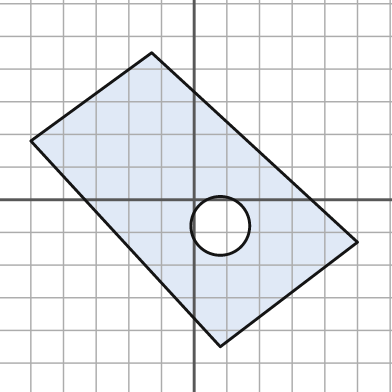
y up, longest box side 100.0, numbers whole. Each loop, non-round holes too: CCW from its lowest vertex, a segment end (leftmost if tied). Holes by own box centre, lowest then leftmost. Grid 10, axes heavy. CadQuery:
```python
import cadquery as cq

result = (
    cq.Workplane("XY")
    .moveTo(8.0, -45.0)
    .lineTo(50.0, -13.0)
    .lineTo(-13.0, 45.0)
    .lineTo(-50.0, 18.0)
    .close()
    .moveTo(8.0, -8.0)
    .circle(9.0)
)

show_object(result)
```